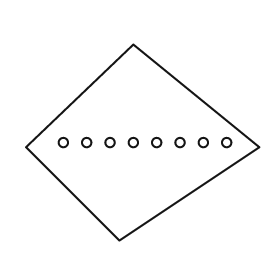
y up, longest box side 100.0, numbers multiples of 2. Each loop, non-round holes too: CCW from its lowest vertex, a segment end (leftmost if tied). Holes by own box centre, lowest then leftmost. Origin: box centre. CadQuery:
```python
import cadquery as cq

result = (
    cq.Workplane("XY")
    .moveTo(-10.0, -42.0)
    .lineTo(50.0, -2.0)
    .lineTo(-4.0, 42.0)
    .lineTo(-50.0, -2.0)
    .close()
    .moveTo(-34.0, 0.0)
    .circle(2.0)
    .moveTo(-24.0, 0.0)
    .circle(2.0)
    .moveTo(-14.0, 0.0)
    .circle(2.0)
    .moveTo(-4.0, 0.0)
    .circle(2.0)
    .moveTo(6.0, 0.0)
    .circle(2.0)
    .moveTo(16.0, 0.0)
    .circle(2.0)
    .moveTo(26.0, 0.0)
    .circle(2.0)
    .moveTo(36.0, 0.0)
    .circle(2.0)
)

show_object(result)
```